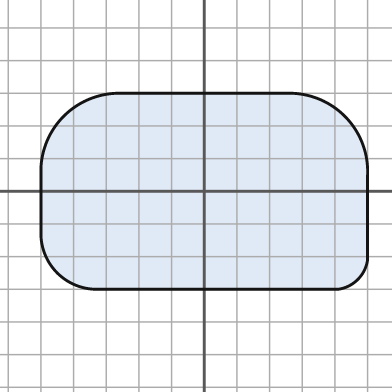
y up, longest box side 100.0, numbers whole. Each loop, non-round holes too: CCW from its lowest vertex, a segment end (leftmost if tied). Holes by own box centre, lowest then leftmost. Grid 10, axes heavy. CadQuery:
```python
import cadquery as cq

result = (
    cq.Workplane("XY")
    .moveTo(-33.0, -30.0)
    .lineTo(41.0, -30.0)
    .threePointArc((47.0, -27.0), (50.0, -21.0))
    .lineTo(50.0, 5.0)
    .threePointArc((43.0, 23.0), (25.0, 30.0))
    .lineTo(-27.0, 30.0)
    .threePointArc((-43.0, 23.0), (-50.0, 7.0))
    .lineTo(-50.0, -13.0)
    .threePointArc((-45.0, -25.0), (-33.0, -30.0))
    .close()
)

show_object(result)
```